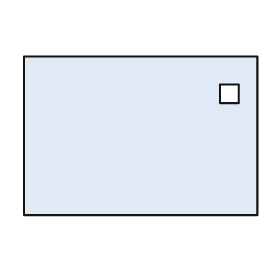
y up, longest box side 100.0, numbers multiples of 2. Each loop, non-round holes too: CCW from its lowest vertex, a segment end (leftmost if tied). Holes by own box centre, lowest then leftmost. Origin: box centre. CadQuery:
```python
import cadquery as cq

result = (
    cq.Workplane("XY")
    .moveTo(-50.0, -34.0)
    .lineTo(50.0, -34.0)
    .lineTo(50.0, 34.0)
    .lineTo(-50.0, 34.0)
    .close()
    .moveTo(34.0, 14.0)
    .lineTo(42.0, 14.0)
    .lineTo(42.0, 22.0)
    .lineTo(34.0, 22.0)
    .close()
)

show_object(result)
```